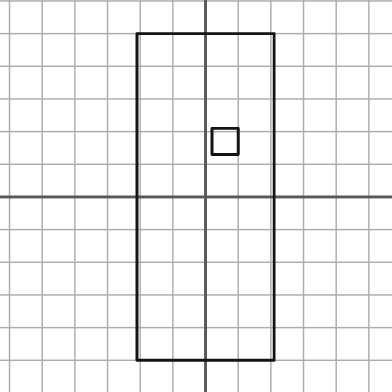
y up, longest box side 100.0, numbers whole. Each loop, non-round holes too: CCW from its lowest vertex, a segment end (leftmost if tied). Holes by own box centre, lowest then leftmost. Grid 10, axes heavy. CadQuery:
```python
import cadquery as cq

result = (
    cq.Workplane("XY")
    .moveTo(-21.0, -50.0)
    .lineTo(21.0, -50.0)
    .lineTo(21.0, 50.0)
    .lineTo(-21.0, 50.0)
    .close()
    .moveTo(2.0, 13.0)
    .lineTo(10.0, 13.0)
    .lineTo(10.0, 21.0)
    .lineTo(2.0, 21.0)
    .close()
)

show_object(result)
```